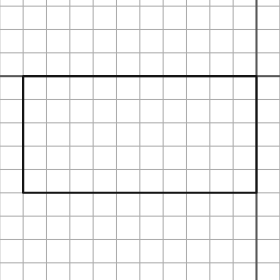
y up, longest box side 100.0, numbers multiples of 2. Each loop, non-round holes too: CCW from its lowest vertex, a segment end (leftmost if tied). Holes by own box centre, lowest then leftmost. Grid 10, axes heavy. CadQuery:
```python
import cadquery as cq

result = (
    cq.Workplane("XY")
    .moveTo(-100.0, -50.0)
    .lineTo(0.0, -50.0)
    .lineTo(0.0, 0.0)
    .lineTo(-100.0, 0.0)
    .close()
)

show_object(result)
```